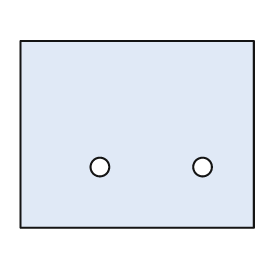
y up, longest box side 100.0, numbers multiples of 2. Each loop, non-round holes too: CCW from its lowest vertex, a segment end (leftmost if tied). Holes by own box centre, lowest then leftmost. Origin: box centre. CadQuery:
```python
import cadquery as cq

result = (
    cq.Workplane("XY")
    .moveTo(-50.0, -40.0)
    .lineTo(50.0, -40.0)
    .lineTo(50.0, 40.0)
    .lineTo(-50.0, 40.0)
    .close()
    .moveTo(-16.0, -14.0)
    .circle(4.0)
    .moveTo(28.0, -14.0)
    .circle(4.0)
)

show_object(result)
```